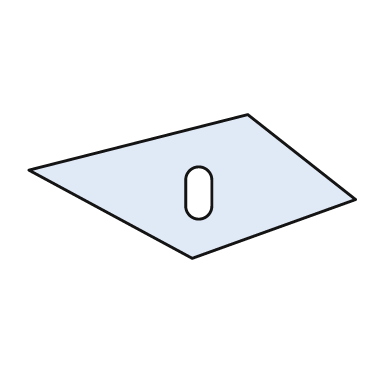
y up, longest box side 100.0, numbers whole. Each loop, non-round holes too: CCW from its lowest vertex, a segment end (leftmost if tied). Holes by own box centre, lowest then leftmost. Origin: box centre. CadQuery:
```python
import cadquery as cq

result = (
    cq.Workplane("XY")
    .moveTo(0.0, -22.0)
    .lineTo(50.0, -4.0)
    .lineTo(17.0, 22.0)
    .lineTo(-50.0, 5.0)
    .close()
    .moveTo(-2.0, -6.0)
    .threePointArc((2.0, -10.0), (6.0, -6.0))
    .lineTo(6.0, 2.0)
    .threePointArc((2.0, 6.0), (-2.0, 2.0))
    .close()
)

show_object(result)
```